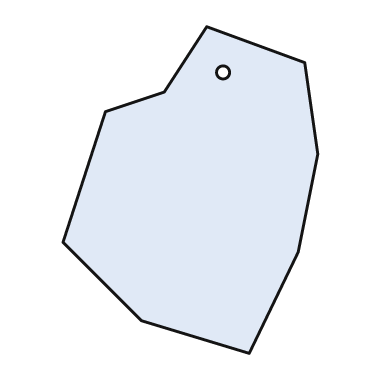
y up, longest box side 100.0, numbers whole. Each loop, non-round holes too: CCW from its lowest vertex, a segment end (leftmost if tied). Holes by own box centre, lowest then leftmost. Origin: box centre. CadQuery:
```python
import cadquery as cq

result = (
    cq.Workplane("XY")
    .moveTo(18.0, -50.0)
    .lineTo(33.0, -19.0)
    .lineTo(39.0, 11.0)
    .lineTo(35.0, 39.0)
    .lineTo(5.0, 50.0)
    .lineTo(-8.0, 30.0)
    .lineTo(-26.0, 24.0)
    .lineTo(-39.0, -16.0)
    .lineTo(-15.0, -40.0)
    .close()
    .moveTo(10.0, 36.0)
    .circle(2.0)
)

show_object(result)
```